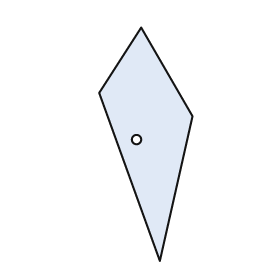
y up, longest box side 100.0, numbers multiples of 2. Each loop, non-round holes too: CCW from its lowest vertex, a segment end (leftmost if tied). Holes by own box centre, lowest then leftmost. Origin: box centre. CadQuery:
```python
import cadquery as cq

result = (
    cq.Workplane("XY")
    .moveTo(6.0, -50.0)
    .lineTo(20.0, 12.0)
    .lineTo(-2.0, 50.0)
    .lineTo(-20.0, 22.0)
    .close()
    .moveTo(-4.0, 2.0)
    .circle(2.0)
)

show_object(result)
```